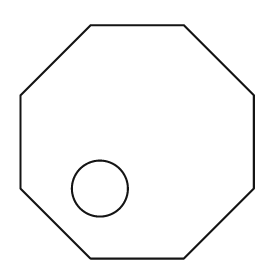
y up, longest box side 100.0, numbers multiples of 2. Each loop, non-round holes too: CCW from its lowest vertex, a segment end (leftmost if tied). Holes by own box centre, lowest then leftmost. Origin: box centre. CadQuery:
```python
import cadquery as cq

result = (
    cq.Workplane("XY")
    .moveTo(-20.0, -50.0)
    .lineTo(20.0, -50.0)
    .lineTo(50.0, -20.0)
    .lineTo(50.0, 20.0)
    .lineTo(20.0, 50.0)
    .lineTo(-20.0, 50.0)
    .lineTo(-50.0, 20.0)
    .lineTo(-50.0, -20.0)
    .close()
    .moveTo(-16.0, -20.0)
    .circle(12.0)
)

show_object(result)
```